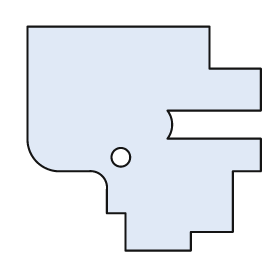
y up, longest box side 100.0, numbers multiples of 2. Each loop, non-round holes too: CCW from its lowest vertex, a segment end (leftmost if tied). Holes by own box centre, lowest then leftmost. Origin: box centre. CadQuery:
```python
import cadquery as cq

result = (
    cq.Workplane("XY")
    .moveTo(-8.0, -48.0)
    .lineTo(20.0, -48.0)
    .lineTo(20.0, -40.0)
    .lineTo(38.0, -40.0)
    .lineTo(38.0, -14.0)
    .lineTo(50.0, -14.0)
    .lineTo(50.0, 0.0)
    .lineTo(10.0, 0.0)
    .threePointArc((12.0, 6.0), (10.0, 12.0))
    .lineTo(50.0, 12.0)
    .lineTo(50.0, 30.0)
    .lineTo(28.0, 30.0)
    .lineTo(28.0, 48.0)
    .lineTo(-50.0, 48.0)
    .lineTo(-50.0, 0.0)
    .threePointArc((-46.0, -10.0), (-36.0, -14.0))
    .lineTo(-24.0, -14.0)
    .threePointArc((-18.0, -16.0), (-16.0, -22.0))
    .lineTo(-16.0, -32.0)
    .lineTo(-8.0, -32.0)
    .close()
    .moveTo(-10.0, -8.0)
    .circle(4.0)
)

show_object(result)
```